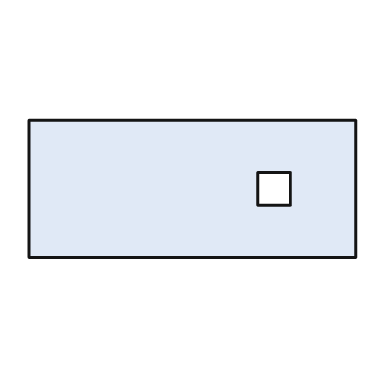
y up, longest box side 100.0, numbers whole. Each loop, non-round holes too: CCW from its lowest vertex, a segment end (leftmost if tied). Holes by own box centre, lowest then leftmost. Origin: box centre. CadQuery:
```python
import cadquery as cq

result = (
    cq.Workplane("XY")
    .moveTo(-50.0, -21.0)
    .lineTo(50.0, -21.0)
    .lineTo(50.0, 21.0)
    .lineTo(-50.0, 21.0)
    .close()
    .moveTo(20.0, -5.0)
    .lineTo(30.0, -5.0)
    .lineTo(30.0, 5.0)
    .lineTo(20.0, 5.0)
    .close()
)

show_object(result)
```